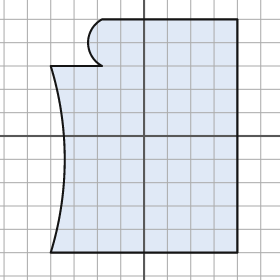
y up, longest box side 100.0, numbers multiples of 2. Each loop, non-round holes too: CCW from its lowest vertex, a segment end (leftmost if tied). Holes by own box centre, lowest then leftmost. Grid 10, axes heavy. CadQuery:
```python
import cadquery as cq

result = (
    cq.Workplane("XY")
    .moveTo(-40.0, -50.0)
    .lineTo(40.0, -50.0)
    .lineTo(40.0, 50.0)
    .lineTo(-18.0, 50.0)
    .threePointArc((-24.0, 40.0), (-18.0, 30.0))
    .lineTo(-40.0, 30.0)
    .threePointArc((-34.0, -10.0), (-40.0, -50.0))
    .close()
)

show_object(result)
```